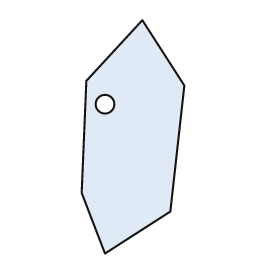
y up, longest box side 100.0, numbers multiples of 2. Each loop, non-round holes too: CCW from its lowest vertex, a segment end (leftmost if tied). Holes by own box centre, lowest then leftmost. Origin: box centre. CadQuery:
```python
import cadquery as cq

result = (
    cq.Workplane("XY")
    .moveTo(-12.0, -50.0)
    .lineTo(16.0, -32.0)
    .lineTo(22.0, 22.0)
    .lineTo(4.0, 50.0)
    .lineTo(-20.0, 24.0)
    .lineTo(-22.0, -24.0)
    .close()
    .moveTo(-12.0, 14.0)
    .circle(4.0)
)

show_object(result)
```